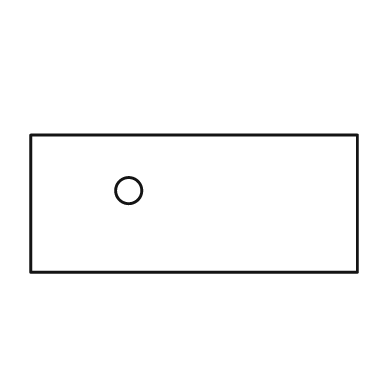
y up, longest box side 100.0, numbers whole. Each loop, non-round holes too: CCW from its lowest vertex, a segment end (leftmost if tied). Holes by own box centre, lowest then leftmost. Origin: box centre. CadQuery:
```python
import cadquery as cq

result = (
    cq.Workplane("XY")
    .moveTo(-50.0, -21.0)
    .lineTo(50.0, -21.0)
    .lineTo(50.0, 21.0)
    .lineTo(-50.0, 21.0)
    .close()
    .moveTo(-20.0, 4.0)
    .circle(4.0)
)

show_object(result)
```